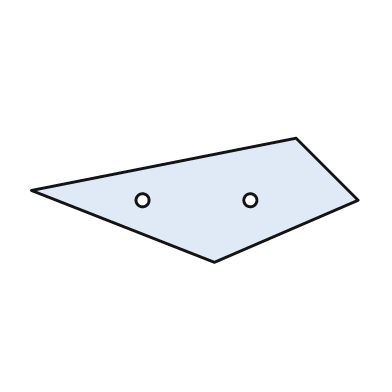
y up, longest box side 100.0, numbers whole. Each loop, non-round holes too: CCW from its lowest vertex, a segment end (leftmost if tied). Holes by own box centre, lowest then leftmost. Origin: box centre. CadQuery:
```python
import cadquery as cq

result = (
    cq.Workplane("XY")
    .moveTo(6.0, -19.0)
    .lineTo(50.0, 0.0)
    .lineTo(31.0, 19.0)
    .lineTo(-50.0, 3.0)
    .close()
    .moveTo(-16.0, 0.0)
    .circle(2.0)
    .moveTo(17.0, 0.0)
    .circle(2.0)
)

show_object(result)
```